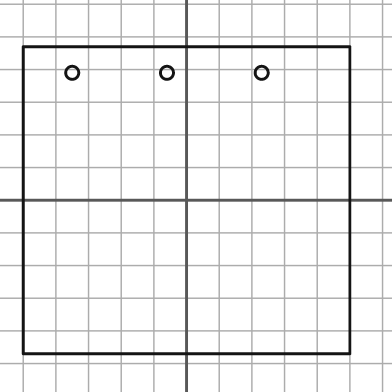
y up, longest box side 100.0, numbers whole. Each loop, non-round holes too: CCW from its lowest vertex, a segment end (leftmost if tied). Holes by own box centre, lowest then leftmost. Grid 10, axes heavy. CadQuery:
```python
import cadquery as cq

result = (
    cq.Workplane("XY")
    .moveTo(-50.0, -47.0)
    .lineTo(50.0, -47.0)
    .lineTo(50.0, 47.0)
    .lineTo(-50.0, 47.0)
    .close()
    .moveTo(-35.0, 39.0)
    .circle(2.0)
    .moveTo(-6.0, 39.0)
    .circle(2.0)
    .moveTo(23.0, 39.0)
    .circle(2.0)
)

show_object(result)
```